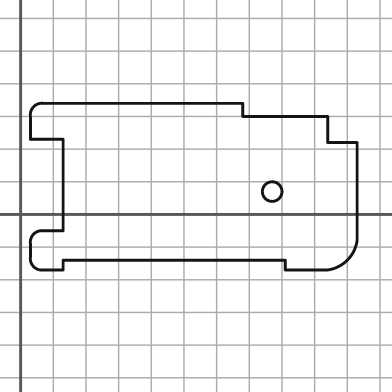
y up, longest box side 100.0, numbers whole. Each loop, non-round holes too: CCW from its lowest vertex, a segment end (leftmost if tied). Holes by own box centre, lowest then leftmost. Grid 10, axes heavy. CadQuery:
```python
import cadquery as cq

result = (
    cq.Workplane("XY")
    .moveTo(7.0, -17.0)
    .lineTo(13.0, -17.0)
    .lineTo(13.0, -14.0)
    .lineTo(81.0, -14.0)
    .lineTo(81.0, -17.0)
    .lineTo(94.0, -17.0)
    .threePointArc((100.0, -14.0), (103.0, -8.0))
    .lineTo(103.0, 22.0)
    .lineTo(94.0, 22.0)
    .lineTo(94.0, 30.0)
    .lineTo(68.0, 30.0)
    .lineTo(68.0, 34.0)
    .lineTo(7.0, 34.0)
    .threePointArc((4.0, 33.0), (3.0, 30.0))
    .lineTo(3.0, 23.0)
    .lineTo(13.0, 23.0)
    .lineTo(13.0, -5.0)
    .lineTo(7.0, -5.0)
    .threePointArc((4.0, -6.0), (3.0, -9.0))
    .lineTo(3.0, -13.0)
    .threePointArc((4.0, -16.0), (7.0, -17.0))
    .close()
    .moveTo(77.0, 7.0)
    .circle(3.0)
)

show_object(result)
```